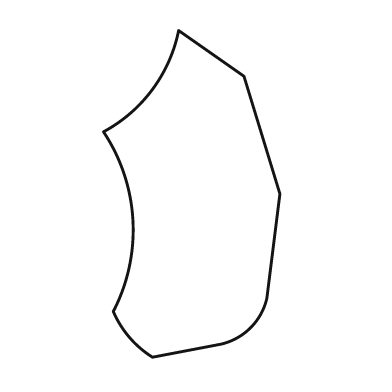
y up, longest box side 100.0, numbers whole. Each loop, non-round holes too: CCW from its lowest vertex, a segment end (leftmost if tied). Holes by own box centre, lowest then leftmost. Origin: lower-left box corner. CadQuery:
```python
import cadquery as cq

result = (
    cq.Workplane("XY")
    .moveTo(15.0, 0.0)
    .lineTo(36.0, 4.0)
    .threePointArc((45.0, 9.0), (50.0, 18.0))
    .lineTo(54.0, 50.0)
    .lineTo(43.0, 86.0)
    .lineTo(23.0, 100.0)
    .threePointArc((15.0, 82.0), (0.0, 69.0))
    .threePointArc((9.0, 42.0), (3.0, 14.0))
    .threePointArc((8.0, 6.0), (15.0, 0.0))
    .close()
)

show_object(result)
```